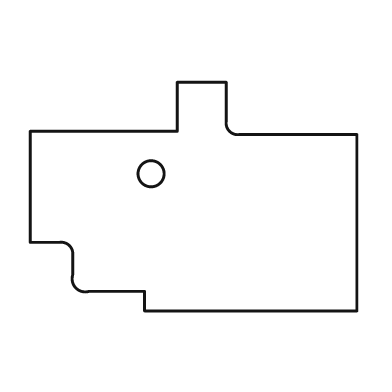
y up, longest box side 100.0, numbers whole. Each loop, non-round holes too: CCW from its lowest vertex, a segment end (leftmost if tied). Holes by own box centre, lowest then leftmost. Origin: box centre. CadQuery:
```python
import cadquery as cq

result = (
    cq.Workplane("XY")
    .moveTo(-15.0, -35.0)
    .lineTo(50.0, -35.0)
    .lineTo(50.0, 19.0)
    .lineTo(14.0, 19.0)
    .threePointArc((11.0, 20.0), (10.0, 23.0))
    .lineTo(10.0, 35.0)
    .lineTo(-5.0, 35.0)
    .lineTo(-5.0, 20.0)
    .lineTo(-50.0, 20.0)
    .lineTo(-50.0, -14.0)
    .lineTo(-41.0, -14.0)
    .threePointArc((-38.0, -15.0), (-37.0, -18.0))
    .lineTo(-37.0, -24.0)
    .threePointArc((-36.0, -28.0), (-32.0, -29.0))
    .lineTo(-15.0, -29.0)
    .close()
    .moveTo(-13.0, 7.0)
    .circle(4.0)
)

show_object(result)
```